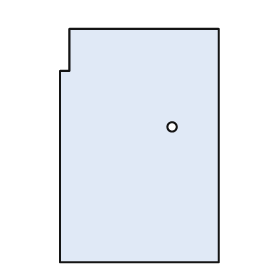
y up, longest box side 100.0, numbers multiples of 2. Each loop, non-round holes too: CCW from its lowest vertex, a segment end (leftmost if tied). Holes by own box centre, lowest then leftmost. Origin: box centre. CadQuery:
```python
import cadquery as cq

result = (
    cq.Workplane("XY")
    .moveTo(-34.0, -50.0)
    .lineTo(34.0, -50.0)
    .lineTo(34.0, 50.0)
    .lineTo(-30.0, 50.0)
    .lineTo(-30.0, 32.0)
    .lineTo(-34.0, 32.0)
    .close()
    .moveTo(14.0, 8.0)
    .circle(2.0)
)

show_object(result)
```